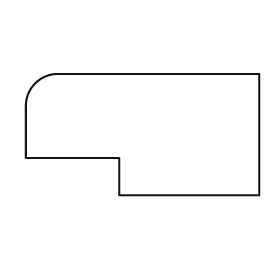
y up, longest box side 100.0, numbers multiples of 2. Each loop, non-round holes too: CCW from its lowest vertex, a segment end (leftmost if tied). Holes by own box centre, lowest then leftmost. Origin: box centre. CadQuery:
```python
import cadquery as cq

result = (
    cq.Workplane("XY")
    .moveTo(-10.0, -26.0)
    .lineTo(50.0, -26.0)
    .lineTo(50.0, 26.0)
    .lineTo(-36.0, 26.0)
    .threePointArc((-46.0, 22.0), (-50.0, 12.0))
    .lineTo(-50.0, -10.0)
    .lineTo(-10.0, -10.0)
    .close()
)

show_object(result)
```